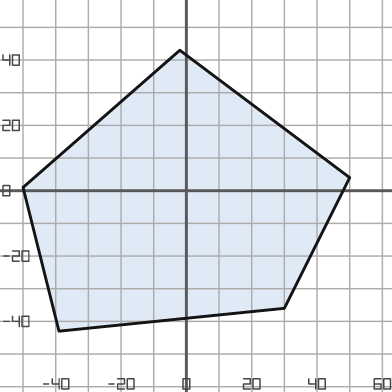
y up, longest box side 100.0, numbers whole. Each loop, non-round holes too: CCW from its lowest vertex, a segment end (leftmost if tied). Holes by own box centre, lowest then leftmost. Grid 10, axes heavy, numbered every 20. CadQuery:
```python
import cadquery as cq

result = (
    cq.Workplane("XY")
    .moveTo(-39.0, -43.0)
    .lineTo(30.0, -36.0)
    .lineTo(50.0, 4.0)
    .lineTo(-2.0, 43.0)
    .lineTo(-50.0, 1.0)
    .close()
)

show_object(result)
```